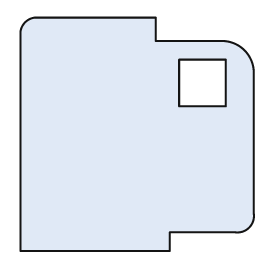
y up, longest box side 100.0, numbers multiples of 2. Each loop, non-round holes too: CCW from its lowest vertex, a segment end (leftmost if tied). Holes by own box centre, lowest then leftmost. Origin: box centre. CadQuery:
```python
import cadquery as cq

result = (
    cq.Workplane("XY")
    .moveTo(-50.0, -50.0)
    .lineTo(14.0, -50.0)
    .lineTo(14.0, -42.0)
    .lineTo(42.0, -42.0)
    .threePointArc((48.0, -40.0), (50.0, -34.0))
    .lineTo(50.0, 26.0)
    .threePointArc((46.0, 36.0), (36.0, 40.0))
    .lineTo(8.0, 40.0)
    .lineTo(8.0, 50.0)
    .lineTo(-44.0, 50.0)
    .threePointArc((-48.0, 48.0), (-50.0, 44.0))
    .close()
    .moveTo(18.0, 12.0)
    .lineTo(38.0, 12.0)
    .lineTo(38.0, 32.0)
    .lineTo(18.0, 32.0)
    .close()
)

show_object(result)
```